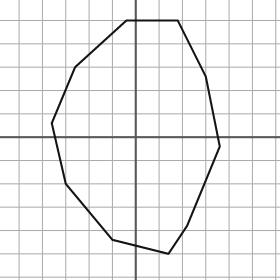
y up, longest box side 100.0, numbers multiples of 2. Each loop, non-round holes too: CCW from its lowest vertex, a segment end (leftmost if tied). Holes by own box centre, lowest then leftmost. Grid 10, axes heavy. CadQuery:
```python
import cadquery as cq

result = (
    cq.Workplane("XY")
    .moveTo(14.0, -50.0)
    .lineTo(22.0, -38.0)
    .lineTo(36.0, -4.0)
    .lineTo(30.0, 26.0)
    .lineTo(18.0, 50.0)
    .lineTo(-4.0, 50.0)
    .lineTo(-26.0, 30.0)
    .lineTo(-36.0, 6.0)
    .lineTo(-30.0, -20.0)
    .lineTo(-10.0, -44.0)
    .close()
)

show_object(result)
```